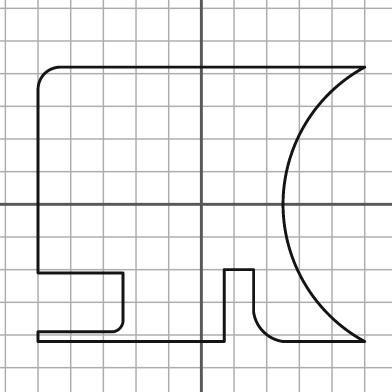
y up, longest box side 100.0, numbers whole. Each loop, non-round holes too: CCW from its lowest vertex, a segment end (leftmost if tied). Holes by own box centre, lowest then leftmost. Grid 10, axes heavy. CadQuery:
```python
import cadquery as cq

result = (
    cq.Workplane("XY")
    .moveTo(-50.0, -42.0)
    .lineTo(7.0, -42.0)
    .lineTo(7.0, -20.0)
    .lineTo(16.0, -20.0)
    .lineTo(16.0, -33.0)
    .threePointArc((19.0, -39.0), (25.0, -42.0))
    .lineTo(50.0, -42.0)
    .threePointArc((25.0, 0.0), (50.0, 42.0))
    .lineTo(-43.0, 42.0)
    .threePointArc((-48.0, 40.0), (-50.0, 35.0))
    .lineTo(-50.0, -21.0)
    .lineTo(-24.0, -21.0)
    .lineTo(-24.0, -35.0)
    .threePointArc((-25.0, -38.0), (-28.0, -39.0))
    .lineTo(-50.0, -39.0)
    .close()
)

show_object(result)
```